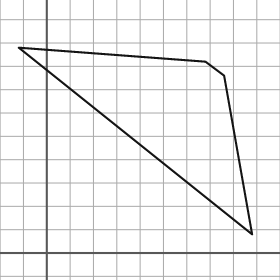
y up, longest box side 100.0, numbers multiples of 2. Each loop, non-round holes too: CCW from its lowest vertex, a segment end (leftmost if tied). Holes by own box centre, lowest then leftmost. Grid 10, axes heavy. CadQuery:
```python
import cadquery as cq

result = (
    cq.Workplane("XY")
    .moveTo(88.0, 8.0)
    .lineTo(76.0, 76.0)
    .lineTo(68.0, 82.0)
    .lineTo(-12.0, 88.0)
    .close()
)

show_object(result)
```